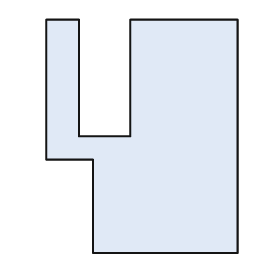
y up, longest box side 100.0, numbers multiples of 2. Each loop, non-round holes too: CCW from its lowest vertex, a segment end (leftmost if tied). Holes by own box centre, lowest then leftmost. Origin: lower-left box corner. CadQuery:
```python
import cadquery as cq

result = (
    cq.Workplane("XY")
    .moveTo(20.0, 0.0)
    .lineTo(82.0, 0.0)
    .lineTo(82.0, 100.0)
    .lineTo(36.0, 100.0)
    .lineTo(36.0, 50.0)
    .lineTo(14.0, 50.0)
    .lineTo(14.0, 100.0)
    .lineTo(0.0, 100.0)
    .lineTo(0.0, 40.0)
    .lineTo(20.0, 40.0)
    .close()
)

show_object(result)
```